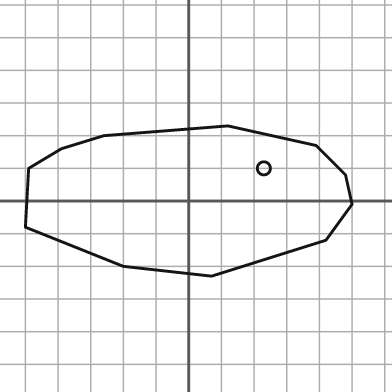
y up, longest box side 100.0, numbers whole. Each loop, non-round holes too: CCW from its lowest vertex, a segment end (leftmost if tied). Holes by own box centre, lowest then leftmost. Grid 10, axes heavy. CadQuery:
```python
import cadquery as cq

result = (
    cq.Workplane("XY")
    .moveTo(7.0, -23.0)
    .lineTo(42.0, -12.0)
    .lineTo(50.0, -1.0)
    .lineTo(48.0, 8.0)
    .lineTo(39.0, 17.0)
    .lineTo(12.0, 23.0)
    .lineTo(-26.0, 20.0)
    .lineTo(-39.0, 16.0)
    .lineTo(-49.0, 10.0)
    .lineTo(-50.0, -8.0)
    .lineTo(-20.0, -20.0)
    .close()
    .moveTo(23.0, 10.0)
    .circle(2.0)
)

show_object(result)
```